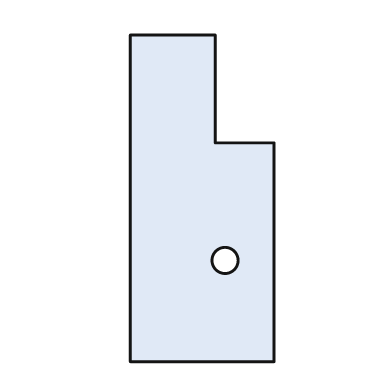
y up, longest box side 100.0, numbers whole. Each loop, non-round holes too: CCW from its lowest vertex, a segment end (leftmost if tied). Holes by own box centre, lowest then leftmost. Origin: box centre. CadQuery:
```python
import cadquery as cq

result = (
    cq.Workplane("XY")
    .moveTo(-22.0, -50.0)
    .lineTo(22.0, -50.0)
    .lineTo(22.0, 17.0)
    .lineTo(4.0, 17.0)
    .lineTo(4.0, 50.0)
    .lineTo(-22.0, 50.0)
    .close()
    .moveTo(7.0, -19.0)
    .circle(4.0)
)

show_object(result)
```